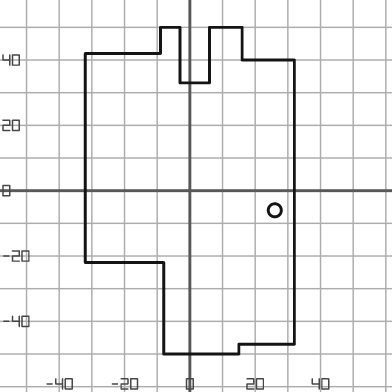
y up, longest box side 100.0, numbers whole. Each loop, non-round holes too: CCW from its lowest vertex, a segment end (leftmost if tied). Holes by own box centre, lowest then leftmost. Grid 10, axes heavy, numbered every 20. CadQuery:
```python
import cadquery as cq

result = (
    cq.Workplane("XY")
    .moveTo(-8.0, -50.0)
    .lineTo(15.0, -50.0)
    .lineTo(15.0, -47.0)
    .lineTo(32.0, -47.0)
    .lineTo(32.0, 40.0)
    .lineTo(16.0, 40.0)
    .lineTo(16.0, 50.0)
    .lineTo(6.0, 50.0)
    .lineTo(6.0, 33.0)
    .lineTo(-3.0, 33.0)
    .lineTo(-3.0, 50.0)
    .lineTo(-9.0, 50.0)
    .lineTo(-9.0, 42.0)
    .lineTo(-32.0, 42.0)
    .lineTo(-32.0, -22.0)
    .lineTo(-8.0, -22.0)
    .close()
    .moveTo(26.0, -6.0)
    .circle(2.0)
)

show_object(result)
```